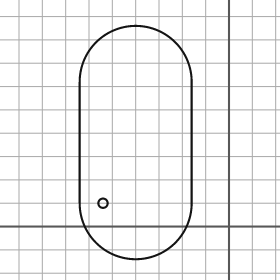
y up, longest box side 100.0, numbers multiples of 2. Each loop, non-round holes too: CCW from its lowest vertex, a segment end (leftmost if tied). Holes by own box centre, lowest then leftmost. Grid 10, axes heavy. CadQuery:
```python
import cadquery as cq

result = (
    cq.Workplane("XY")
    .moveTo(-64.0, 10.0)
    .threePointArc((-40.0, -14.0), (-16.0, 10.0))
    .lineTo(-16.0, 62.0)
    .threePointArc((-40.0, 86.0), (-64.0, 62.0))
    .close()
    .moveTo(-54.0, 10.0)
    .circle(2.0)
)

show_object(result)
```